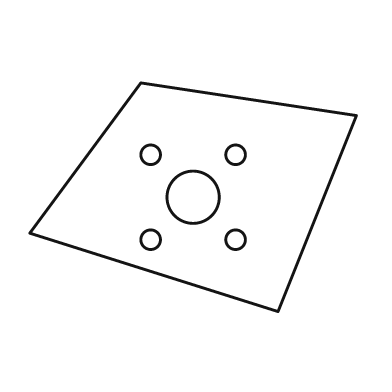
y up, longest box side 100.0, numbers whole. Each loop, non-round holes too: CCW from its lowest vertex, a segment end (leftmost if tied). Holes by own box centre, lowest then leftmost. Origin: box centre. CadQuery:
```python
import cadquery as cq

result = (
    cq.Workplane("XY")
    .moveTo(26.0, -35.0)
    .lineTo(50.0, 25.0)
    .lineTo(-16.0, 35.0)
    .lineTo(-50.0, -11.0)
    .close()
    .moveTo(-13.0, -13.0)
    .circle(3.0)
    .moveTo(13.0, -13.0)
    .circle(3.0)
    .moveTo(0.0, 0.0)
    .circle(8.0)
    .moveTo(-13.0, 13.0)
    .circle(3.0)
    .moveTo(13.0, 13.0)
    .circle(3.0)
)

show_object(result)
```